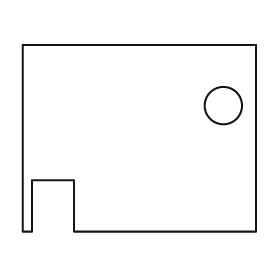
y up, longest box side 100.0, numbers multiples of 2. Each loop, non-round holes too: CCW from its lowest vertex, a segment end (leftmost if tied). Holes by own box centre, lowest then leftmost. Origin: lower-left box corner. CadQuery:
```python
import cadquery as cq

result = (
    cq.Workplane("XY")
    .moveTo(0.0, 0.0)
    .lineTo(4.0, 0.0)
    .lineTo(4.0, 22.0)
    .lineTo(22.0, 22.0)
    .lineTo(22.0, 0.0)
    .lineTo(100.0, 0.0)
    .lineTo(100.0, 80.0)
    .lineTo(0.0, 80.0)
    .close()
    .moveTo(86.0, 54.0)
    .circle(8.0)
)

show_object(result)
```